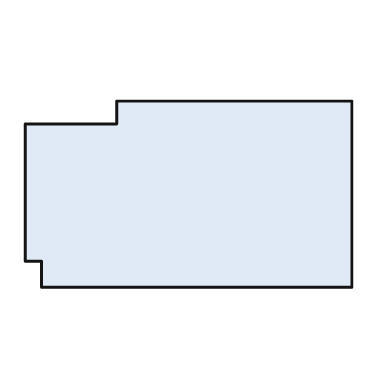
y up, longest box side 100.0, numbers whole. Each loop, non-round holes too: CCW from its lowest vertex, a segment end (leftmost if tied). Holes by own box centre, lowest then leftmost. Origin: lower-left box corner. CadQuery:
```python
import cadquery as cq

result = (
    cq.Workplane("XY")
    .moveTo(5.0, 0.0)
    .lineTo(100.0, 0.0)
    .lineTo(100.0, 57.0)
    .lineTo(28.0, 57.0)
    .lineTo(28.0, 50.0)
    .lineTo(0.0, 50.0)
    .lineTo(0.0, 8.0)
    .lineTo(5.0, 8.0)
    .close()
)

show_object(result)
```